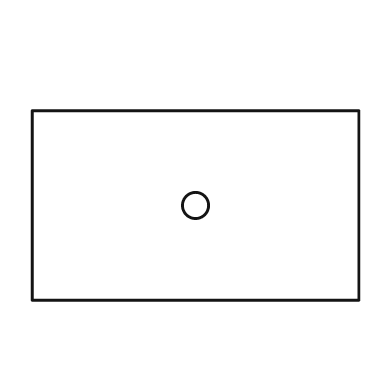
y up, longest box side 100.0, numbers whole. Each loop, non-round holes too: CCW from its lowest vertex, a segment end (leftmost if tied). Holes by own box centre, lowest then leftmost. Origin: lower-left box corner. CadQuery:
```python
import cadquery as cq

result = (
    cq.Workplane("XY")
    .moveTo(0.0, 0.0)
    .lineTo(100.0, 0.0)
    .lineTo(100.0, 58.0)
    .lineTo(0.0, 58.0)
    .close()
    .moveTo(50.0, 29.0)
    .circle(4.0)
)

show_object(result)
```